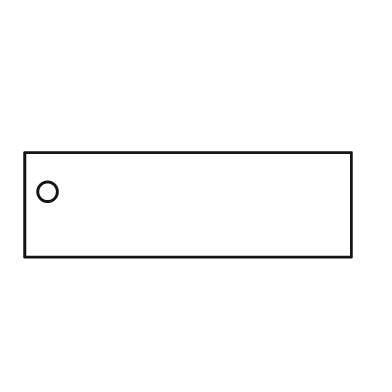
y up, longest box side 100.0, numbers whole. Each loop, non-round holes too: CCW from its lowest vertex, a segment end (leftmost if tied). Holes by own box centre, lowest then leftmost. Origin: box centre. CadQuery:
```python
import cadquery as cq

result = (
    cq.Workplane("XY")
    .moveTo(-50.0, -16.0)
    .lineTo(50.0, -16.0)
    .lineTo(50.0, 16.0)
    .lineTo(-50.0, 16.0)
    .close()
    .moveTo(-43.0, 4.0)
    .circle(3.0)
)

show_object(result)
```